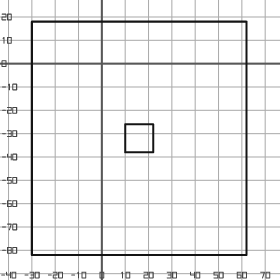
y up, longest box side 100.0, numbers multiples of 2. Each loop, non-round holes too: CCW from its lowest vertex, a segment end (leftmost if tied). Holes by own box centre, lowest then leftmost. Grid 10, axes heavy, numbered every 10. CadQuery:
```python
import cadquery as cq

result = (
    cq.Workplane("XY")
    .moveTo(-30.0, -82.0)
    .lineTo(62.0, -82.0)
    .lineTo(62.0, 18.0)
    .lineTo(-30.0, 18.0)
    .close()
    .moveTo(10.0, -38.0)
    .lineTo(22.0, -38.0)
    .lineTo(22.0, -26.0)
    .lineTo(10.0, -26.0)
    .close()
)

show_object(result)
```